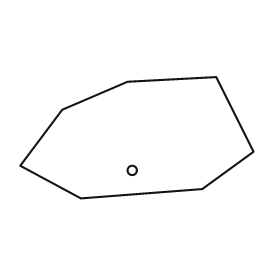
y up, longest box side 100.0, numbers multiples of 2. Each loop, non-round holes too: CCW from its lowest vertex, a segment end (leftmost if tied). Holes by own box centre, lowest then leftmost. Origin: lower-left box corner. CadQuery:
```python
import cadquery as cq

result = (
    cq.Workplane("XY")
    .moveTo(26.0, 0.0)
    .lineTo(78.0, 4.0)
    .lineTo(100.0, 20.0)
    .lineTo(84.0, 52.0)
    .lineTo(46.0, 50.0)
    .lineTo(18.0, 38.0)
    .lineTo(0.0, 14.0)
    .close()
    .moveTo(48.0, 12.0)
    .circle(2.0)
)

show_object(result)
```